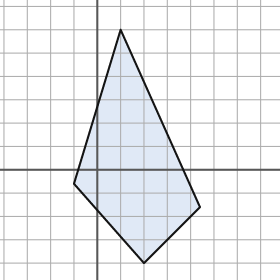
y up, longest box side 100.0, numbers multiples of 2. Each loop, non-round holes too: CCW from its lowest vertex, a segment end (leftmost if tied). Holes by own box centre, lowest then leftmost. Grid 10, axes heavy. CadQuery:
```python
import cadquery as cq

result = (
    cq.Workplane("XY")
    .moveTo(20.0, -40.0)
    .lineTo(44.0, -16.0)
    .lineTo(10.0, 60.0)
    .lineTo(-10.0, -6.0)
    .close()
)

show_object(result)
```